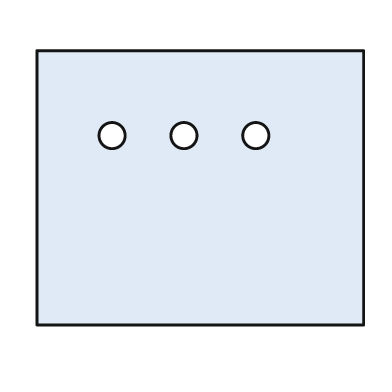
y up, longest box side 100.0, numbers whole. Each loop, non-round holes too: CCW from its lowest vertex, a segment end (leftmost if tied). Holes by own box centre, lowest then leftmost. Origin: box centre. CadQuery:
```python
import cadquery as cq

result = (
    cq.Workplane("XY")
    .moveTo(-50.0, -42.0)
    .lineTo(50.0, -42.0)
    .lineTo(50.0, 42.0)
    .lineTo(-50.0, 42.0)
    .close()
    .moveTo(-27.0, 16.0)
    .circle(4.0)
    .moveTo(-5.0, 16.0)
    .circle(4.0)
    .moveTo(17.0, 16.0)
    .circle(4.0)
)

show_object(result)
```